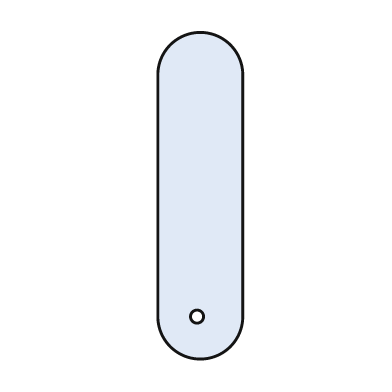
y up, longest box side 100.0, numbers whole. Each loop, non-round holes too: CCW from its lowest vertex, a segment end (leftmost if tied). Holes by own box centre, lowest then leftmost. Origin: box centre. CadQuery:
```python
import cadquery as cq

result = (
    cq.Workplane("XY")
    .moveTo(-13.0, -37.0)
    .threePointArc((0.0, -50.0), (13.0, -37.0))
    .lineTo(13.0, 37.0)
    .threePointArc((0.0, 50.0), (-13.0, 37.0))
    .close()
    .moveTo(-1.0, -37.0)
    .circle(2.0)
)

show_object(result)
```